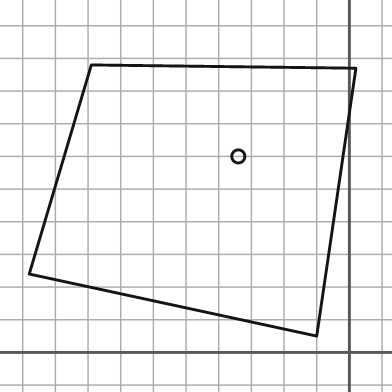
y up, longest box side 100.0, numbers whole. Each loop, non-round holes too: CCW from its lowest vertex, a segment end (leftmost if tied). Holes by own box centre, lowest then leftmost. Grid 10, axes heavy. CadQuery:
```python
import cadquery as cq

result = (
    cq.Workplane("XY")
    .moveTo(-10.0, 5.0)
    .lineTo(2.0, 87.0)
    .lineTo(-79.0, 88.0)
    .lineTo(-98.0, 24.0)
    .close()
    .moveTo(-34.0, 60.0)
    .circle(2.0)
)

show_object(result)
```